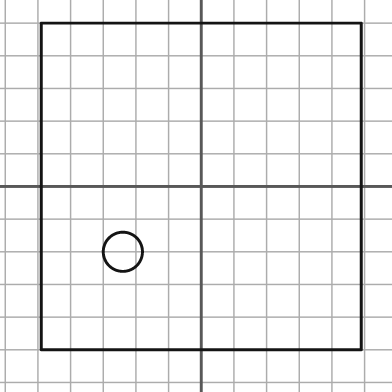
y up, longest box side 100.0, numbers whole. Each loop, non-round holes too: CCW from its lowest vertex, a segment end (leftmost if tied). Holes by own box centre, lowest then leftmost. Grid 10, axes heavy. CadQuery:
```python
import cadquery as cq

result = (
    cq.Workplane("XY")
    .moveTo(-49.0, -50.0)
    .lineTo(49.0, -50.0)
    .lineTo(49.0, 50.0)
    .lineTo(-49.0, 50.0)
    .close()
    .moveTo(-24.0, -20.0)
    .circle(6.0)
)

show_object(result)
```